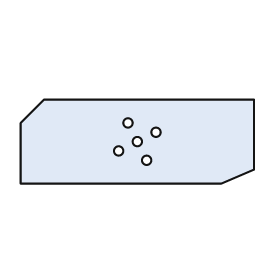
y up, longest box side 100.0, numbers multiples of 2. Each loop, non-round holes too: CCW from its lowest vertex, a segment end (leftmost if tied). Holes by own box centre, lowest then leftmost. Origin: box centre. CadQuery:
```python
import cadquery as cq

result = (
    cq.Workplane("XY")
    .moveTo(-50.0, -18.0)
    .lineTo(36.0, -18.0)
    .lineTo(50.0, -12.0)
    .lineTo(50.0, 18.0)
    .lineTo(-40.0, 18.0)
    .lineTo(-50.0, 8.0)
    .close()
    .moveTo(4.0, -8.0)
    .circle(2.0)
    .moveTo(-8.0, -4.0)
    .circle(2.0)
    .moveTo(0.0, 0.0)
    .circle(2.0)
    .moveTo(8.0, 4.0)
    .circle(2.0)
    .moveTo(-4.0, 8.0)
    .circle(2.0)
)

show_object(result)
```